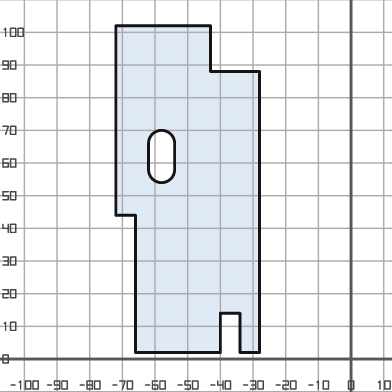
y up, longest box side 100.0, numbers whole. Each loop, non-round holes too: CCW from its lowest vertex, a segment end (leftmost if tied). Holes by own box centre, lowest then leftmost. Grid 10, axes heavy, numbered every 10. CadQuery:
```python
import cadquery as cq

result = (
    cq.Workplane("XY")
    .moveTo(-66.0, 2.0)
    .lineTo(-40.0, 2.0)
    .lineTo(-40.0, 14.0)
    .lineTo(-34.0, 14.0)
    .lineTo(-34.0, 2.0)
    .lineTo(-28.0, 2.0)
    .lineTo(-28.0, 88.0)
    .lineTo(-43.0, 88.0)
    .lineTo(-43.0, 102.0)
    .lineTo(-72.0, 102.0)
    .lineTo(-72.0, 44.0)
    .lineTo(-66.0, 44.0)
    .close()
    .moveTo(-62.0, 58.0)
    .threePointArc((-58.0, 54.0), (-54.0, 58.0))
    .lineTo(-54.0, 66.0)
    .threePointArc((-58.0, 70.0), (-62.0, 66.0))
    .close()
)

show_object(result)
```